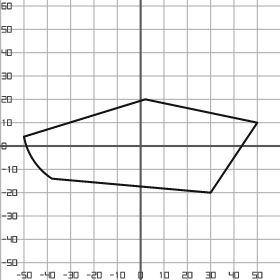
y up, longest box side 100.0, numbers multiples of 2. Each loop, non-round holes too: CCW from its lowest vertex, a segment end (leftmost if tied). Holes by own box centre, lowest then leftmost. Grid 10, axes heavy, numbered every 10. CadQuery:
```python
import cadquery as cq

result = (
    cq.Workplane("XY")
    .moveTo(30.0, -20.0)
    .lineTo(50.0, 10.0)
    .lineTo(2.0, 20.0)
    .lineTo(-50.0, 4.0)
    .threePointArc((-46.0, -6.0), (-38.0, -14.0))
    .close()
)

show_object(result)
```